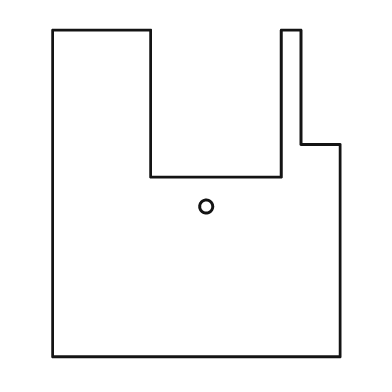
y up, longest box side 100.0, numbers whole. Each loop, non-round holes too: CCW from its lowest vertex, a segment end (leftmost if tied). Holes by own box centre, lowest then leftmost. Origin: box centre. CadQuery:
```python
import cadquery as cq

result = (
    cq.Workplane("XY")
    .moveTo(-44.0, -50.0)
    .lineTo(44.0, -50.0)
    .lineTo(44.0, 15.0)
    .lineTo(32.0, 15.0)
    .lineTo(32.0, 50.0)
    .lineTo(26.0, 50.0)
    .lineTo(26.0, 5.0)
    .lineTo(-14.0, 5.0)
    .lineTo(-14.0, 50.0)
    .lineTo(-44.0, 50.0)
    .close()
    .moveTo(3.0, -4.0)
    .circle(2.0)
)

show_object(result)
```